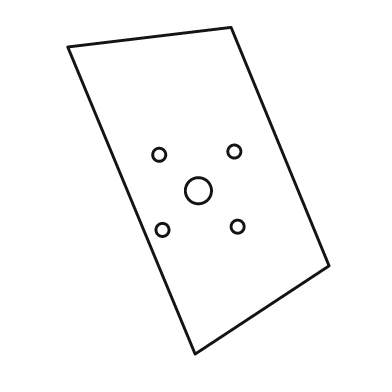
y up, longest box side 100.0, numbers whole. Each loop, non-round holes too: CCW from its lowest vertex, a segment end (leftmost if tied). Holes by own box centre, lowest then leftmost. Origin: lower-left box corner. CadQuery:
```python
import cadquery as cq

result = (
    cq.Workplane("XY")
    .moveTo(39.0, 0.0)
    .lineTo(80.0, 27.0)
    .lineTo(50.0, 100.0)
    .lineTo(0.0, 94.0)
    .close()
    .moveTo(29.0, 38.0)
    .circle(2.0)
    .moveTo(52.0, 39.0)
    .circle(2.0)
    .moveTo(40.0, 50.0)
    .circle(4.0)
    .moveTo(28.0, 61.0)
    .circle(2.0)
    .moveTo(51.0, 62.0)
    .circle(2.0)
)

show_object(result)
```